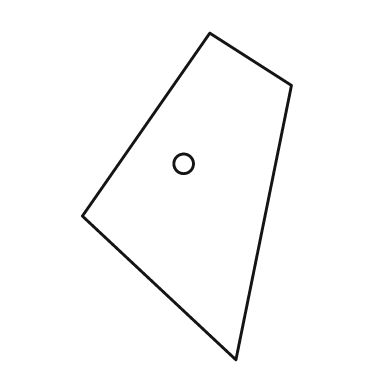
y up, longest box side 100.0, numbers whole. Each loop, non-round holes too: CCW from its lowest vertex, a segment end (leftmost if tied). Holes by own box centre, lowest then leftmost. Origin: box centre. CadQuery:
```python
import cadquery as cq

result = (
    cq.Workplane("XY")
    .moveTo(15.0, -50.0)
    .lineTo(32.0, 34.0)
    .lineTo(7.0, 50.0)
    .lineTo(-32.0, -6.0)
    .close()
    .moveTo(-1.0, 10.0)
    .circle(3.0)
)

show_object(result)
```